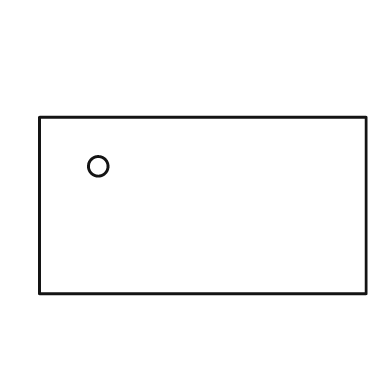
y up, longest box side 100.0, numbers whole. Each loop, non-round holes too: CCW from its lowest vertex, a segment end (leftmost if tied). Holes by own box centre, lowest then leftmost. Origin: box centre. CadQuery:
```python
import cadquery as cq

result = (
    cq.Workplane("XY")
    .moveTo(-50.0, -27.0)
    .lineTo(50.0, -27.0)
    .lineTo(50.0, 27.0)
    .lineTo(-50.0, 27.0)
    .close()
    .moveTo(-32.0, 12.0)
    .circle(3.0)
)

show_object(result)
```